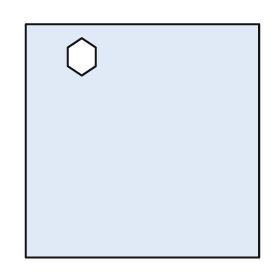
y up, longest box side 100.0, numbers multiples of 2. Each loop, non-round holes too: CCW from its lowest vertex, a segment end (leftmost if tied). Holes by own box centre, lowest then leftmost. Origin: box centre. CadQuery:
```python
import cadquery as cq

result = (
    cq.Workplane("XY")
    .moveTo(-50.0, -50.0)
    .lineTo(50.0, -50.0)
    .lineTo(50.0, 50.0)
    .lineTo(-50.0, 50.0)
    .close()
    .moveTo(-26.0, 28.0)
    .lineTo(-20.0, 32.0)
    .lineTo(-20.0, 40.0)
    .lineTo(-26.0, 44.0)
    .lineTo(-32.0, 40.0)
    .lineTo(-32.0, 32.0)
    .close()
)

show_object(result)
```